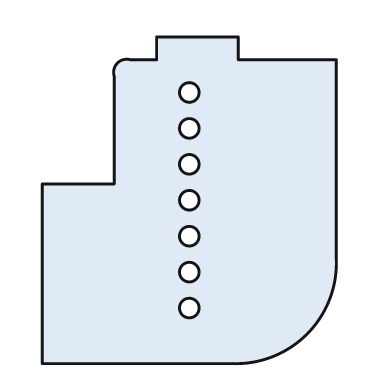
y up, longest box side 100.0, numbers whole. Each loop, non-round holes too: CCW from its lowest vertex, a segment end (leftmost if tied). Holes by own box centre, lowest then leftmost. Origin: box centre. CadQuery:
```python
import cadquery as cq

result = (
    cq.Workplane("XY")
    .moveTo(-45.0, -50.0)
    .lineTo(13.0, -50.0)
    .threePointArc((36.0, -41.0), (45.0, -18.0))
    .lineTo(45.0, 43.0)
    .lineTo(15.0, 43.0)
    .lineTo(15.0, 50.0)
    .lineTo(-10.0, 50.0)
    .lineTo(-10.0, 43.0)
    .lineTo(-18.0, 43.0)
    .threePointArc((-22.0, 42.0), (-23.0, 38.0))
    .lineTo(-23.0, 5.0)
    .lineTo(-45.0, 5.0)
    .close()
    .moveTo(0.0, -33.0)
    .circle(3.0)
    .moveTo(0.0, -22.0)
    .circle(3.0)
    .moveTo(0.0, -11.0)
    .circle(3.0)
    .moveTo(0.0, 0.0)
    .circle(3.0)
    .moveTo(0.0, 11.0)
    .circle(3.0)
    .moveTo(0.0, 22.0)
    .circle(3.0)
    .moveTo(0.0, 33.0)
    .circle(3.0)
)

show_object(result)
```